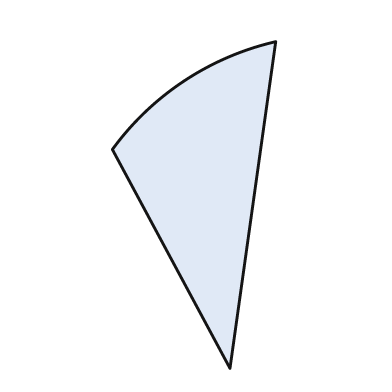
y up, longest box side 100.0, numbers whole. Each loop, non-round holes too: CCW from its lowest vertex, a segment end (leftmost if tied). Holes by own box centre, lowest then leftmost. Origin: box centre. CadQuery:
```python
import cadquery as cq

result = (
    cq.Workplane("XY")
    .moveTo(11.0, -50.0)
    .lineTo(25.0, 50.0)
    .threePointArc((-3.0, 38.0), (-25.0, 17.0))
    .close()
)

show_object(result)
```